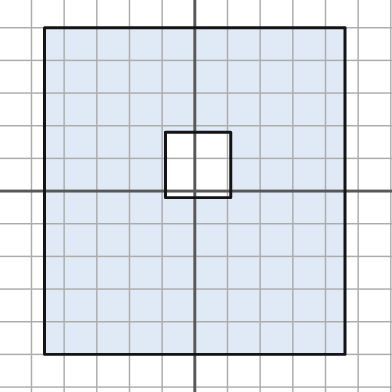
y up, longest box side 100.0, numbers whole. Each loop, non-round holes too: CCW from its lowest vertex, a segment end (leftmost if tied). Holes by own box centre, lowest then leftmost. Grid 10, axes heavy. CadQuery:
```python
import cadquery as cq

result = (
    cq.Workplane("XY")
    .moveTo(-46.0, -50.0)
    .lineTo(46.0, -50.0)
    .lineTo(46.0, 50.0)
    .lineTo(-46.0, 50.0)
    .close()
    .moveTo(-9.0, -2.0)
    .lineTo(11.0, -2.0)
    .lineTo(11.0, 18.0)
    .lineTo(-9.0, 18.0)
    .close()
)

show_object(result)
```